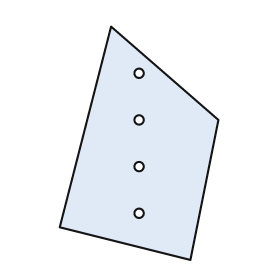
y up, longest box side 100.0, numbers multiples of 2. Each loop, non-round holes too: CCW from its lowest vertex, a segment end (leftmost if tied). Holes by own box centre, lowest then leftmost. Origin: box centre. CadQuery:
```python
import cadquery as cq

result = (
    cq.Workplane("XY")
    .moveTo(22.0, -50.0)
    .lineTo(34.0, 10.0)
    .lineTo(-12.0, 50.0)
    .lineTo(-34.0, -36.0)
    .close()
    .moveTo(0.0, -30.0)
    .circle(2.0)
    .moveTo(0.0, -10.0)
    .circle(2.0)
    .moveTo(0.0, 10.0)
    .circle(2.0)
    .moveTo(0.0, 30.0)
    .circle(2.0)
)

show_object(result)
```